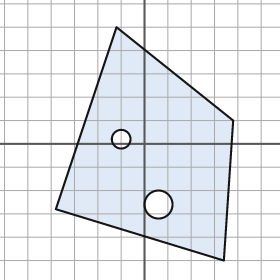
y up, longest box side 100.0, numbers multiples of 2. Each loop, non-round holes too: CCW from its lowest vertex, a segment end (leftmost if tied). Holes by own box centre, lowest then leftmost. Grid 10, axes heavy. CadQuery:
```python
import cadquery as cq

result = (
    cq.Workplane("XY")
    .moveTo(34.0, -50.0)
    .lineTo(38.0, 10.0)
    .lineTo(-12.0, 50.0)
    .lineTo(-38.0, -28.0)
    .close()
    .moveTo(6.0, -26.0)
    .circle(6.0)
    .moveTo(-10.0, 2.0)
    .circle(4.0)
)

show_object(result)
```